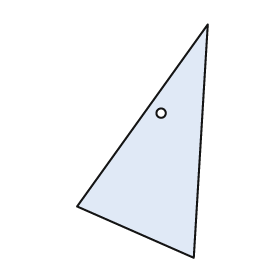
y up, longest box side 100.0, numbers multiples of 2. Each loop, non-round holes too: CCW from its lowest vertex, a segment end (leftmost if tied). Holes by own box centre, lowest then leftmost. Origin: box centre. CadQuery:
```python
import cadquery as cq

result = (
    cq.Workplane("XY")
    .moveTo(22.0, -50.0)
    .lineTo(28.0, 50.0)
    .lineTo(-28.0, -28.0)
    .close()
    .moveTo(8.0, 12.0)
    .circle(2.0)
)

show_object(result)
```